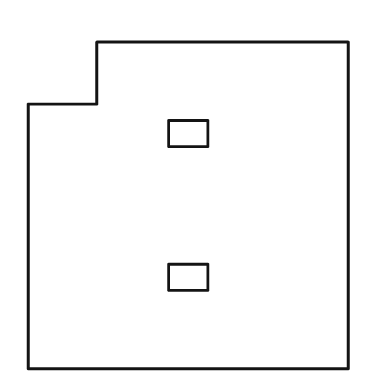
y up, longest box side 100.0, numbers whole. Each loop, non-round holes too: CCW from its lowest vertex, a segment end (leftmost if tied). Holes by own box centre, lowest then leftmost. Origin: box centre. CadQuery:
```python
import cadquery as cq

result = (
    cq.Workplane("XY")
    .moveTo(-49.0, -50.0)
    .lineTo(49.0, -50.0)
    .lineTo(49.0, 50.0)
    .lineTo(-28.0, 50.0)
    .lineTo(-28.0, 31.0)
    .lineTo(-49.0, 31.0)
    .close()
    .moveTo(-6.0, -26.0)
    .lineTo(6.0, -26.0)
    .lineTo(6.0, -18.0)
    .lineTo(-6.0, -18.0)
    .close()
    .moveTo(-6.0, 18.0)
    .lineTo(6.0, 18.0)
    .lineTo(6.0, 26.0)
    .lineTo(-6.0, 26.0)
    .close()
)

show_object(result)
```